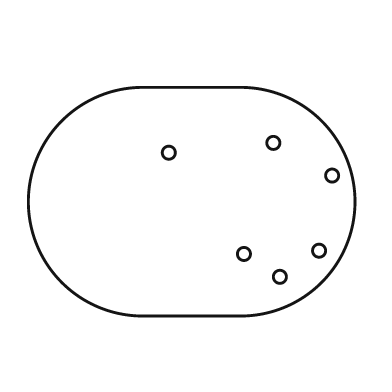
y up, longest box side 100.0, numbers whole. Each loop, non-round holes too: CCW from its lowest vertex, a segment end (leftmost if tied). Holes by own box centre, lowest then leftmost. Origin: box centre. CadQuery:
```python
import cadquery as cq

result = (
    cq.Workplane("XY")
    .moveTo(-15.0, -35.0)
    .lineTo(15.0, -35.0)
    .threePointArc((50.0, 0.0), (15.0, 35.0))
    .lineTo(-15.0, 35.0)
    .threePointArc((-50.0, 0.0), (-15.0, -35.0))
    .close()
    .moveTo(27.0, -23.0)
    .circle(2.0)
    .moveTo(16.0, -16.0)
    .circle(2.0)
    .moveTo(39.0, -15.0)
    .circle(2.0)
    .moveTo(43.0, 8.0)
    .circle(2.0)
    .moveTo(-7.0, 15.0)
    .circle(2.0)
    .moveTo(25.0, 18.0)
    .circle(2.0)
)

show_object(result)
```